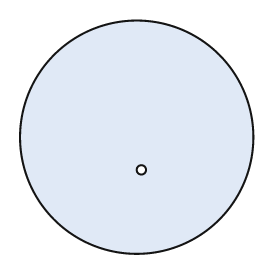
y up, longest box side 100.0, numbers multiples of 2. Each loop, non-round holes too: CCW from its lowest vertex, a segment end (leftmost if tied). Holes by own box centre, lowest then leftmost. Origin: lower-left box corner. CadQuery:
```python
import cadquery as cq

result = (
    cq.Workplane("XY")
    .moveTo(50.0, 50.0)
    .circle(50.0)
    .moveTo(52.0, 36.0)
    .circle(2.0)
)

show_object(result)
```